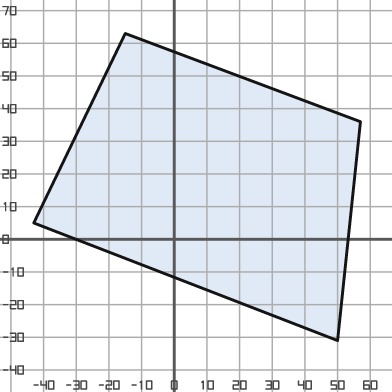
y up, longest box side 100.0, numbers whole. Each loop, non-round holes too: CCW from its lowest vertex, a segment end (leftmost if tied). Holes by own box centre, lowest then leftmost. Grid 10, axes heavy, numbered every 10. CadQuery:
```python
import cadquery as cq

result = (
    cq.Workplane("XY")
    .moveTo(50.0, -31.0)
    .lineTo(57.0, 36.0)
    .lineTo(-15.0, 63.0)
    .lineTo(-43.0, 5.0)
    .close()
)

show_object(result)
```